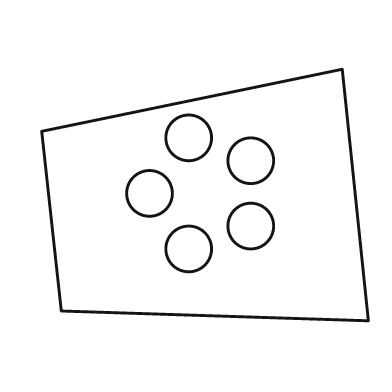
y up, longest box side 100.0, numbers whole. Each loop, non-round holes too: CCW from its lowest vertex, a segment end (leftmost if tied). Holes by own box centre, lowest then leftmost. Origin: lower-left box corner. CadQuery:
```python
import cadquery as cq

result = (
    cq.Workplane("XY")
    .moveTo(100.0, 0.0)
    .lineTo(92.0, 77.0)
    .lineTo(0.0, 58.0)
    .lineTo(6.0, 3.0)
    .close()
    .moveTo(45.0, 22.0)
    .circle(7.0)
    .moveTo(64.0, 29.0)
    .circle(7.0)
    .moveTo(33.0, 39.0)
    .circle(7.0)
    .moveTo(64.0, 49.0)
    .circle(7.0)
    .moveTo(45.0, 56.0)
    .circle(7.0)
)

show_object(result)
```